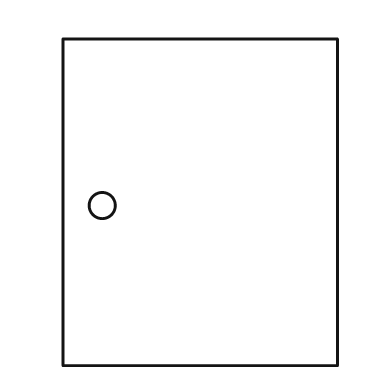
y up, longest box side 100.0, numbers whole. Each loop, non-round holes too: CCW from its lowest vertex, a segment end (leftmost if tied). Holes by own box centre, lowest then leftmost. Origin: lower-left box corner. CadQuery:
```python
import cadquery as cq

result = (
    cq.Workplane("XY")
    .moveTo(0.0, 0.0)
    .lineTo(84.0, 0.0)
    .lineTo(84.0, 100.0)
    .lineTo(0.0, 100.0)
    .close()
    .moveTo(12.0, 49.0)
    .circle(4.0)
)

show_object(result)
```